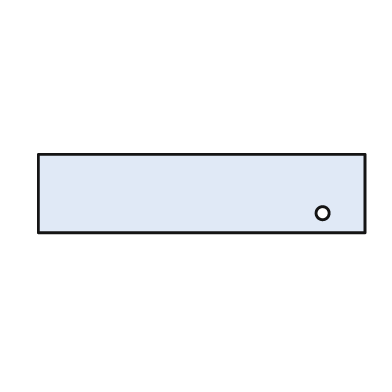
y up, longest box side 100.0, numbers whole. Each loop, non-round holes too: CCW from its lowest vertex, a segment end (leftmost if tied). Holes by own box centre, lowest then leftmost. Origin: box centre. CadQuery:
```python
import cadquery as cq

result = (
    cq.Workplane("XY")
    .moveTo(-50.0, -12.0)
    .lineTo(50.0, -12.0)
    .lineTo(50.0, 12.0)
    .lineTo(-50.0, 12.0)
    .close()
    .moveTo(37.0, -6.0)
    .circle(2.0)
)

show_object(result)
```